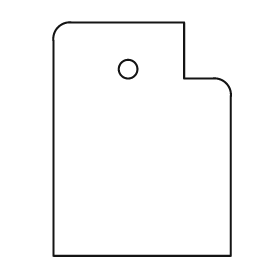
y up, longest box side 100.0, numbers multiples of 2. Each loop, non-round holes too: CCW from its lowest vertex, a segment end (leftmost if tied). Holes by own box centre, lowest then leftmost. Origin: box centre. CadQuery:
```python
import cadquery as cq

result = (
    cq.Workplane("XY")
    .moveTo(-38.0, -50.0)
    .lineTo(38.0, -50.0)
    .lineTo(38.0, 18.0)
    .threePointArc((36.0, 24.0), (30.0, 26.0))
    .lineTo(18.0, 26.0)
    .lineTo(18.0, 50.0)
    .lineTo(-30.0, 50.0)
    .threePointArc((-36.0, 48.0), (-38.0, 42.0))
    .close()
    .moveTo(-6.0, 30.0)
    .circle(4.0)
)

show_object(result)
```